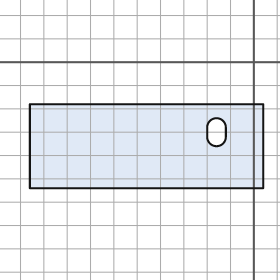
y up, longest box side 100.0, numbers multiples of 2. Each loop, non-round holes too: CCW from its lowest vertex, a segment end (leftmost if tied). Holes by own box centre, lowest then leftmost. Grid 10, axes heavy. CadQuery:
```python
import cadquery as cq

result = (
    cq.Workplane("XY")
    .moveTo(-96.0, -54.0)
    .lineTo(4.0, -54.0)
    .lineTo(4.0, -18.0)
    .lineTo(-96.0, -18.0)
    .close()
    .moveTo(-20.0, -32.0)
    .threePointArc((-16.0, -36.0), (-12.0, -32.0))
    .lineTo(-12.0, -28.0)
    .threePointArc((-16.0, -24.0), (-20.0, -28.0))
    .close()
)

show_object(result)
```